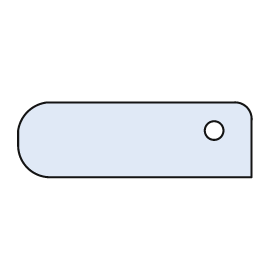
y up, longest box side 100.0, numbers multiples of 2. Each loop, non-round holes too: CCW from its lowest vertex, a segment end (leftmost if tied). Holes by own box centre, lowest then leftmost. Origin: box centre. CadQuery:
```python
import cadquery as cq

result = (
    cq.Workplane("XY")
    .moveTo(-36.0, -16.0)
    .lineTo(50.0, -16.0)
    .lineTo(50.0, 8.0)
    .threePointArc((48.0, 14.0), (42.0, 16.0))
    .lineTo(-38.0, 16.0)
    .threePointArc((-46.0, 12.0), (-50.0, 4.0))
    .lineTo(-50.0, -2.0)
    .threePointArc((-46.0, -12.0), (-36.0, -16.0))
    .close()
    .moveTo(34.0, 4.0)
    .circle(4.0)
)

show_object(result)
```